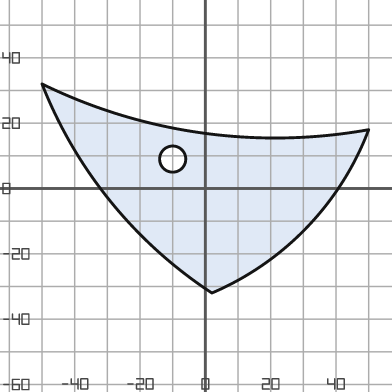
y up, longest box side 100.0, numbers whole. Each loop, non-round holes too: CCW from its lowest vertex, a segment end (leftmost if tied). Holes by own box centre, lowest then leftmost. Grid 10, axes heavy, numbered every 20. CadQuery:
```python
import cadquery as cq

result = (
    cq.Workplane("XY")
    .moveTo(2.0, -32.0)
    .threePointArc((31.0, -12.0), (50.0, 18.0))
    .threePointArc((-1.0, 17.0), (-50.0, 32.0))
    .threePointArc((-29.0, -4.0), (2.0, -32.0))
    .close()
    .moveTo(-10.0, 9.0)
    .circle(4.0)
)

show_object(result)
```